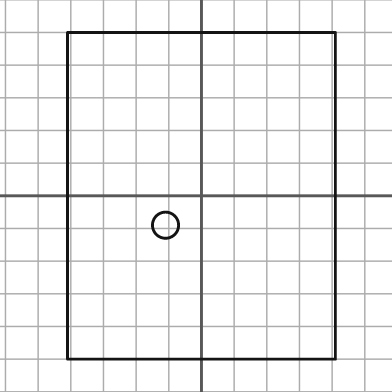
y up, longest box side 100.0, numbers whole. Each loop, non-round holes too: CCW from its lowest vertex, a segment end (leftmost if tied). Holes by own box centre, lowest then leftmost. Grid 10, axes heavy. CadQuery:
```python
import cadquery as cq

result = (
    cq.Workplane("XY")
    .moveTo(-41.0, -50.0)
    .lineTo(41.0, -50.0)
    .lineTo(41.0, 50.0)
    .lineTo(-41.0, 50.0)
    .close()
    .moveTo(-11.0, -9.0)
    .circle(4.0)
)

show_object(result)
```